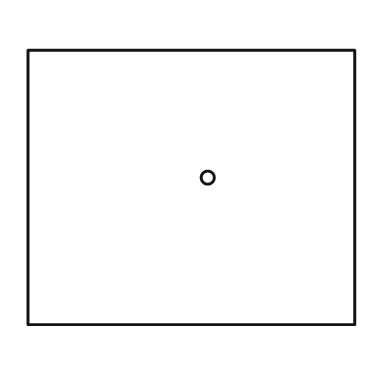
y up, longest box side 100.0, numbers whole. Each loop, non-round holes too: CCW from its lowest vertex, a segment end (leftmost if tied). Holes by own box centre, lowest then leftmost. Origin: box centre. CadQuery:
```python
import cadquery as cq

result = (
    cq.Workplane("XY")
    .moveTo(-50.0, -42.0)
    .lineTo(50.0, -42.0)
    .lineTo(50.0, 42.0)
    .lineTo(-50.0, 42.0)
    .close()
    .moveTo(5.0, 3.0)
    .circle(2.0)
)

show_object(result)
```